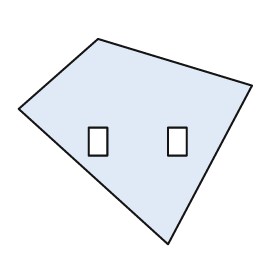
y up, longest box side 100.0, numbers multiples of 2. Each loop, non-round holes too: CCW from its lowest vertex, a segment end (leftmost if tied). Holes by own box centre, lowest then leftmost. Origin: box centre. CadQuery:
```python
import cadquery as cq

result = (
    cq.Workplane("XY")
    .moveTo(14.0, -44.0)
    .lineTo(50.0, 24.0)
    .lineTo(-16.0, 44.0)
    .lineTo(-50.0, 14.0)
    .close()
    .moveTo(-20.0, -6.0)
    .lineTo(-12.0, -6.0)
    .lineTo(-12.0, 6.0)
    .lineTo(-20.0, 6.0)
    .close()
    .moveTo(14.0, -6.0)
    .lineTo(22.0, -6.0)
    .lineTo(22.0, 6.0)
    .lineTo(14.0, 6.0)
    .close()
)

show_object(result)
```